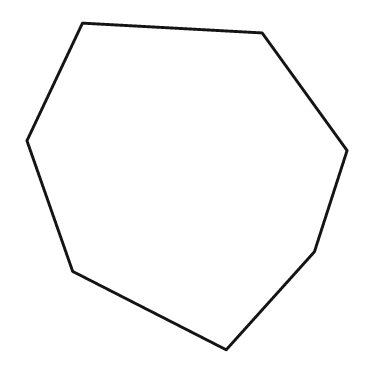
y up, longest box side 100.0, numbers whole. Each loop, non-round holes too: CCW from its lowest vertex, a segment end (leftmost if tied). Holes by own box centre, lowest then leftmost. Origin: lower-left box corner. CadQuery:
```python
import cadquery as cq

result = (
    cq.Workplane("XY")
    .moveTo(61.0, 0.0)
    .lineTo(88.0, 30.0)
    .lineTo(98.0, 61.0)
    .lineTo(72.0, 97.0)
    .lineTo(17.0, 100.0)
    .lineTo(0.0, 64.0)
    .lineTo(14.0, 24.0)
    .close()
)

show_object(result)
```